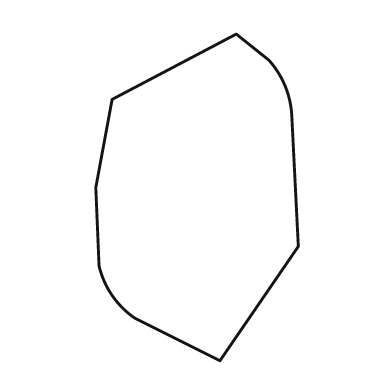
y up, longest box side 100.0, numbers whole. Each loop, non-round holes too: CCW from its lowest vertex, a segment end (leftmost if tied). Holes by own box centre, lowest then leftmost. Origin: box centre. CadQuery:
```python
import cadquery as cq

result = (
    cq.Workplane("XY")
    .moveTo(7.0, -50.0)
    .lineTo(31.0, -15.0)
    .lineTo(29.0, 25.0)
    .threePointArc((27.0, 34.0), (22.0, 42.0))
    .lineTo(12.0, 50.0)
    .lineTo(-26.0, 30.0)
    .lineTo(-31.0, 3.0)
    .lineTo(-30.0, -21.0)
    .threePointArc((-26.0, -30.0), (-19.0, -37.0))
    .close()
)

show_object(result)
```